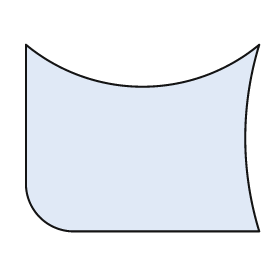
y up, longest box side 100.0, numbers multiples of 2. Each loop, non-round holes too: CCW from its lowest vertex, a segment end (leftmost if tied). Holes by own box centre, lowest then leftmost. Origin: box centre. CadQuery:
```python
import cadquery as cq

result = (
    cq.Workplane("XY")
    .moveTo(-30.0, -40.0)
    .lineTo(50.0, -40.0)
    .threePointArc((44.0, 0.0), (50.0, 40.0))
    .threePointArc((0.0, 22.0), (-50.0, 40.0))
    .lineTo(-50.0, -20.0)
    .threePointArc((-44.0, -34.0), (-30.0, -40.0))
    .close()
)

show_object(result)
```